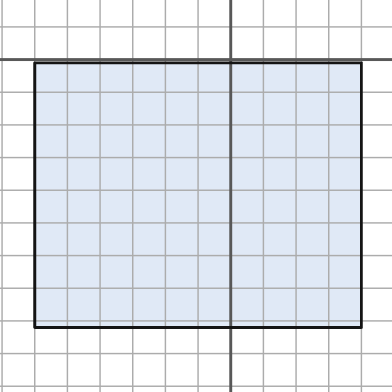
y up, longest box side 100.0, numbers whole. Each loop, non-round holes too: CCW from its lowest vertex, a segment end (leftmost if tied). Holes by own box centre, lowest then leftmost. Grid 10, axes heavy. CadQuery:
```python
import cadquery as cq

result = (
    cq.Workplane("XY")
    .moveTo(-60.0, -82.0)
    .lineTo(40.0, -82.0)
    .lineTo(40.0, -1.0)
    .lineTo(-60.0, -1.0)
    .close()
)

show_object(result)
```